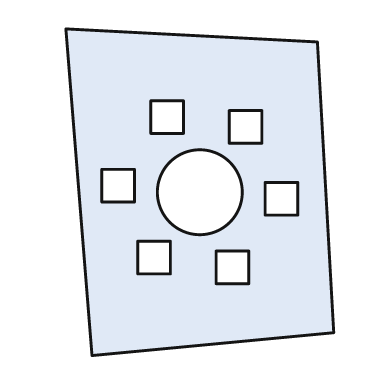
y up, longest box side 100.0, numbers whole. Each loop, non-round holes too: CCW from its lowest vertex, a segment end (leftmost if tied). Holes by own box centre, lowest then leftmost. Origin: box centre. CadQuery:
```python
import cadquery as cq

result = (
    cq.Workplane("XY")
    .moveTo(-33.0, -50.0)
    .lineTo(41.0, -43.0)
    .lineTo(36.0, 46.0)
    .lineTo(-41.0, 50.0)
    .close()
    .moveTo(5.0, -28.0)
    .lineTo(15.0, -28.0)
    .lineTo(15.0, -18.0)
    .lineTo(5.0, -18.0)
    .close()
    .moveTo(-19.0, -25.0)
    .lineTo(-9.0, -25.0)
    .lineTo(-9.0, -15.0)
    .lineTo(-19.0, -15.0)
    .close()
    .moveTo(20.0, -7.0)
    .lineTo(30.0, -7.0)
    .lineTo(30.0, 3.0)
    .lineTo(20.0, 3.0)
    .close()
    .moveTo(0.0, 0.0)
    .circle(13.0)
    .moveTo(-30.0, -3.0)
    .lineTo(-20.0, -3.0)
    .lineTo(-20.0, 7.0)
    .lineTo(-30.0, 7.0)
    .close()
    .moveTo(9.0, 15.0)
    .lineTo(19.0, 15.0)
    .lineTo(19.0, 25.0)
    .lineTo(9.0, 25.0)
    .close()
    .moveTo(-15.0, 18.0)
    .lineTo(-5.0, 18.0)
    .lineTo(-5.0, 28.0)
    .lineTo(-15.0, 28.0)
    .close()
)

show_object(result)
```